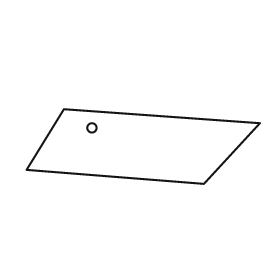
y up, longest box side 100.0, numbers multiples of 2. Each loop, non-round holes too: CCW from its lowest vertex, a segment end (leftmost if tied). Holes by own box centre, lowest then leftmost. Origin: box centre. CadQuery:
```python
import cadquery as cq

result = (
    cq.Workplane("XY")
    .moveTo(26.0, -16.0)
    .lineTo(50.0, 10.0)
    .lineTo(-34.0, 16.0)
    .lineTo(-50.0, -10.0)
    .close()
    .moveTo(-22.0, 8.0)
    .circle(2.0)
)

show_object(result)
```